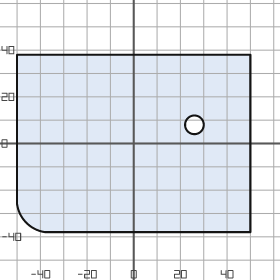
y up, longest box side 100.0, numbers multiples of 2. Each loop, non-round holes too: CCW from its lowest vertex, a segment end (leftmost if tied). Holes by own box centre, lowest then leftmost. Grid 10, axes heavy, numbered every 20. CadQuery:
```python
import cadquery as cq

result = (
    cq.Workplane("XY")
    .moveTo(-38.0, -38.0)
    .lineTo(50.0, -38.0)
    .lineTo(50.0, 38.0)
    .lineTo(-50.0, 38.0)
    .lineTo(-50.0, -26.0)
    .threePointArc((-46.0, -34.0), (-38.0, -38.0))
    .close()
    .moveTo(26.0, 8.0)
    .circle(4.0)
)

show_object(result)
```